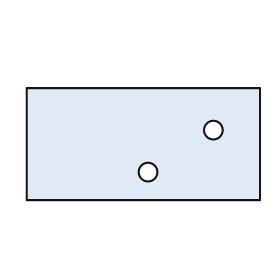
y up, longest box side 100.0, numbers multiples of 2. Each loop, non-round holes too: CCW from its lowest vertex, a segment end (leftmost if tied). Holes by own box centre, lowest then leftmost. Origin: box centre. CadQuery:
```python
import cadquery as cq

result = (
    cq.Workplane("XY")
    .moveTo(-50.0, -24.0)
    .lineTo(50.0, -24.0)
    .lineTo(50.0, 24.0)
    .lineTo(-50.0, 24.0)
    .close()
    .moveTo(2.0, -12.0)
    .circle(4.0)
    .moveTo(30.0, 6.0)
    .circle(4.0)
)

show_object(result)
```